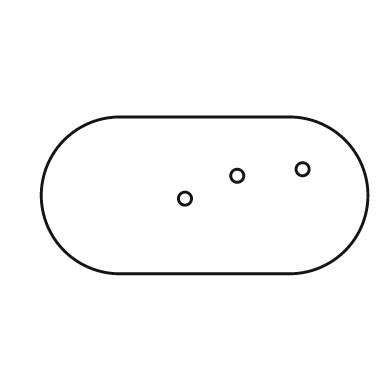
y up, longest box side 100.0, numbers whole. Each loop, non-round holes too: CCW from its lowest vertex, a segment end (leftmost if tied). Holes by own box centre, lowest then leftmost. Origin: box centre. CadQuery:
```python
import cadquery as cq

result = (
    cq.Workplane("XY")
    .moveTo(-26.0, -24.0)
    .lineTo(26.0, -24.0)
    .threePointArc((50.0, 0.0), (26.0, 24.0))
    .lineTo(-26.0, 24.0)
    .threePointArc((-50.0, 0.0), (-26.0, -24.0))
    .close()
    .moveTo(-6.0, -1.0)
    .circle(2.0)
    .moveTo(10.0, 6.0)
    .circle(2.0)
    .moveTo(30.0, 8.0)
    .circle(2.0)
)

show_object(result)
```